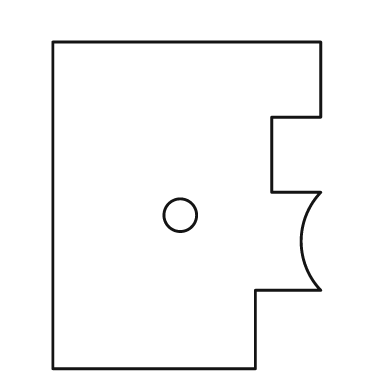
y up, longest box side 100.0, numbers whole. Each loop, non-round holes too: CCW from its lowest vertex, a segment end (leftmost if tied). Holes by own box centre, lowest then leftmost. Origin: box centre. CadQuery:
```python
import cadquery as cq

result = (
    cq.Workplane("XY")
    .moveTo(-41.0, -50.0)
    .lineTo(21.0, -50.0)
    .lineTo(21.0, -26.0)
    .lineTo(41.0, -26.0)
    .threePointArc((35.0, -11.0), (41.0, 4.0))
    .lineTo(26.0, 4.0)
    .lineTo(26.0, 27.0)
    .lineTo(41.0, 27.0)
    .lineTo(41.0, 50.0)
    .lineTo(-41.0, 50.0)
    .close()
    .moveTo(-2.0, -3.0)
    .circle(5.0)
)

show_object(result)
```